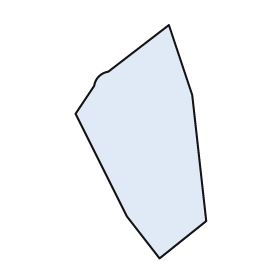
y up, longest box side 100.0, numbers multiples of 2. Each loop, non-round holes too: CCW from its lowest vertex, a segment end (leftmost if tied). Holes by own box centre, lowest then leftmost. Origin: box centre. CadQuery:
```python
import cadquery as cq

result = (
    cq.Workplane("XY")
    .moveTo(8.0, -50.0)
    .lineTo(28.0, -34.0)
    .lineTo(22.0, 20.0)
    .lineTo(12.0, 50.0)
    .lineTo(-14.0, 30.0)
    .threePointArc((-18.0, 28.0), (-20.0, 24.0))
    .lineTo(-28.0, 12.0)
    .lineTo(-6.0, -32.0)
    .close()
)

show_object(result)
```